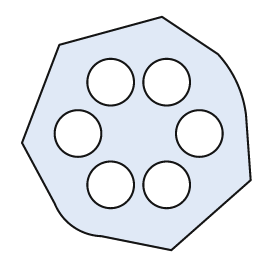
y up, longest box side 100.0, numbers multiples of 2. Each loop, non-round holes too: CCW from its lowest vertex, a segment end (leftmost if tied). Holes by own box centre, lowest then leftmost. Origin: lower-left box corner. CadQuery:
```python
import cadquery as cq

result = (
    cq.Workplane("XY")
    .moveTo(64.0, 0.0)
    .lineTo(98.0, 30.0)
    .lineTo(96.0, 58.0)
    .threePointArc((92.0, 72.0), (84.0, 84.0))
    .lineTo(60.0, 100.0)
    .lineTo(16.0, 88.0)
    .lineTo(0.0, 46.0)
    .lineTo(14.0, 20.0)
    .threePointArc((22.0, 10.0), (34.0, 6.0))
    .close()
    .moveTo(38.0, 28.0)
    .circle(10.0)
    .moveTo(62.0, 28.0)
    .circle(10.0)
    .moveTo(24.0, 50.0)
    .circle(10.0)
    .moveTo(76.0, 50.0)
    .circle(10.0)
    .moveTo(38.0, 72.0)
    .circle(10.0)
    .moveTo(62.0, 72.0)
    .circle(10.0)
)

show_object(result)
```